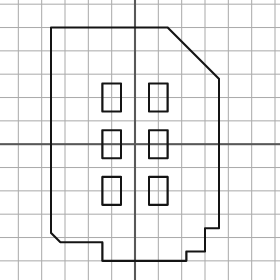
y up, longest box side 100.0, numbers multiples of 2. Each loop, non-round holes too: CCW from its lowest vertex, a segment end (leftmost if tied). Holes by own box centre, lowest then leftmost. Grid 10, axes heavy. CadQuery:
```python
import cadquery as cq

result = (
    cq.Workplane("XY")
    .moveTo(-14.0, -50.0)
    .lineTo(22.0, -50.0)
    .lineTo(22.0, -46.0)
    .lineTo(30.0, -46.0)
    .lineTo(30.0, -36.0)
    .lineTo(36.0, -36.0)
    .lineTo(36.0, 28.0)
    .lineTo(14.0, 50.0)
    .lineTo(-36.0, 50.0)
    .lineTo(-36.0, -38.0)
    .lineTo(-32.0, -42.0)
    .lineTo(-14.0, -42.0)
    .close()
    .moveTo(-14.0, -26.0)
    .lineTo(-6.0, -26.0)
    .lineTo(-6.0, -14.0)
    .lineTo(-14.0, -14.0)
    .close()
    .moveTo(6.0, -26.0)
    .lineTo(14.0, -26.0)
    .lineTo(14.0, -14.0)
    .lineTo(6.0, -14.0)
    .close()
    .moveTo(-14.0, -6.0)
    .lineTo(-6.0, -6.0)
    .lineTo(-6.0, 6.0)
    .lineTo(-14.0, 6.0)
    .close()
    .moveTo(6.0, -6.0)
    .lineTo(14.0, -6.0)
    .lineTo(14.0, 6.0)
    .lineTo(6.0, 6.0)
    .close()
    .moveTo(-14.0, 14.0)
    .lineTo(-6.0, 14.0)
    .lineTo(-6.0, 26.0)
    .lineTo(-14.0, 26.0)
    .close()
    .moveTo(6.0, 14.0)
    .lineTo(14.0, 14.0)
    .lineTo(14.0, 26.0)
    .lineTo(6.0, 26.0)
    .close()
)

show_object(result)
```